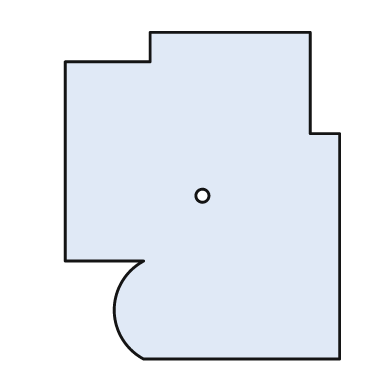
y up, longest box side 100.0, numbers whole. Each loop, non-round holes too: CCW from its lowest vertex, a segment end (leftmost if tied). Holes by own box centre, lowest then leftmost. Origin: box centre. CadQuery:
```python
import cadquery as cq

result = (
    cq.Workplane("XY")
    .moveTo(-18.0, -50.0)
    .lineTo(42.0, -50.0)
    .lineTo(42.0, 19.0)
    .lineTo(33.0, 19.0)
    .lineTo(33.0, 50.0)
    .lineTo(-16.0, 50.0)
    .lineTo(-16.0, 41.0)
    .lineTo(-42.0, 41.0)
    .lineTo(-42.0, -20.0)
    .lineTo(-18.0, -20.0)
    .threePointArc((-27.0, -35.0), (-18.0, -50.0))
    .close()
    .moveTo(0.0, 0.0)
    .circle(2.0)
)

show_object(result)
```